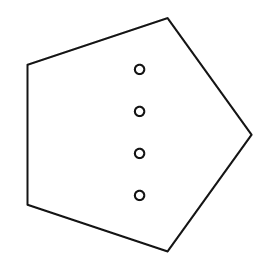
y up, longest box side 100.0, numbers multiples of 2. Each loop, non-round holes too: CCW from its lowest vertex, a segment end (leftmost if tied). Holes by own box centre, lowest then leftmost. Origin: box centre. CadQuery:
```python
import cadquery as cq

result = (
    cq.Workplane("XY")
    .moveTo(12.0, -50.0)
    .lineTo(48.0, 0.0)
    .lineTo(12.0, 50.0)
    .lineTo(-48.0, 30.0)
    .lineTo(-48.0, -30.0)
    .close()
    .moveTo(0.0, -26.0)
    .circle(2.0)
    .moveTo(0.0, -8.0)
    .circle(2.0)
    .moveTo(0.0, 10.0)
    .circle(2.0)
    .moveTo(0.0, 28.0)
    .circle(2.0)
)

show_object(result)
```